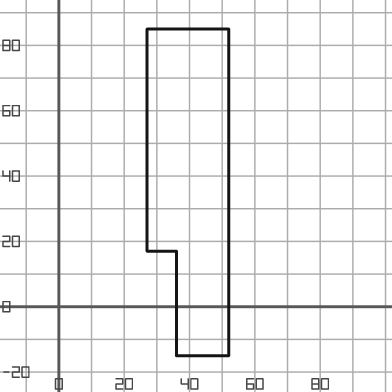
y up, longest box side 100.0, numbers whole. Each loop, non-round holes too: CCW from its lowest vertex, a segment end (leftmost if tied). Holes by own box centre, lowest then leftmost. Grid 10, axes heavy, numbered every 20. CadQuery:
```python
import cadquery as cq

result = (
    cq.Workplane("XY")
    .moveTo(36.0, -15.0)
    .lineTo(52.0, -15.0)
    .lineTo(52.0, 85.0)
    .lineTo(27.0, 85.0)
    .lineTo(27.0, 17.0)
    .lineTo(36.0, 17.0)
    .close()
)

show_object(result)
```